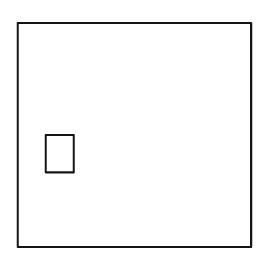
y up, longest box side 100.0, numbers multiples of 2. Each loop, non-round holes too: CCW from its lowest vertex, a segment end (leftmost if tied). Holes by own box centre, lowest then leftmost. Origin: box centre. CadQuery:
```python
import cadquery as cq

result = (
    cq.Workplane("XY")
    .moveTo(-50.0, -48.0)
    .lineTo(50.0, -48.0)
    .lineTo(50.0, 48.0)
    .lineTo(-50.0, 48.0)
    .close()
    .moveTo(-38.0, -16.0)
    .lineTo(-26.0, -16.0)
    .lineTo(-26.0, 0.0)
    .lineTo(-38.0, 0.0)
    .close()
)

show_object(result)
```